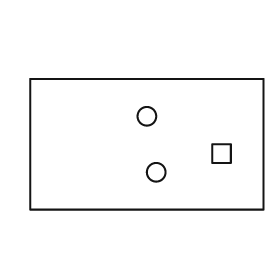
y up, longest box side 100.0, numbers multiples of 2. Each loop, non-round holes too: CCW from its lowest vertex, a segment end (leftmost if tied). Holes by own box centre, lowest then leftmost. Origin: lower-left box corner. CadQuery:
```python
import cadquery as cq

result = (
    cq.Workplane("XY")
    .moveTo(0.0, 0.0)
    .lineTo(100.0, 0.0)
    .lineTo(100.0, 56.0)
    .lineTo(0.0, 56.0)
    .close()
    .moveTo(54.0, 16.0)
    .circle(4.0)
    .moveTo(78.0, 20.0)
    .lineTo(86.0, 20.0)
    .lineTo(86.0, 28.0)
    .lineTo(78.0, 28.0)
    .close()
    .moveTo(50.0, 40.0)
    .circle(4.0)
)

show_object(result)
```